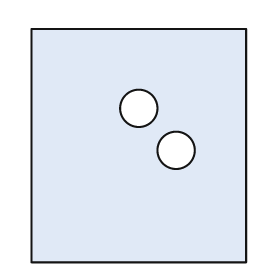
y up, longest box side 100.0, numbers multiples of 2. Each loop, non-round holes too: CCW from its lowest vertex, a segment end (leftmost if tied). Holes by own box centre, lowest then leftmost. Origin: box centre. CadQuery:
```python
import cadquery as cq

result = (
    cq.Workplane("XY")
    .moveTo(-46.0, -50.0)
    .lineTo(46.0, -50.0)
    .lineTo(46.0, 50.0)
    .lineTo(-46.0, 50.0)
    .close()
    .moveTo(16.0, -2.0)
    .circle(8.0)
    .moveTo(0.0, 16.0)
    .circle(8.0)
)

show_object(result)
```